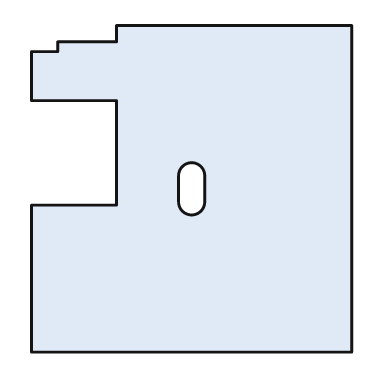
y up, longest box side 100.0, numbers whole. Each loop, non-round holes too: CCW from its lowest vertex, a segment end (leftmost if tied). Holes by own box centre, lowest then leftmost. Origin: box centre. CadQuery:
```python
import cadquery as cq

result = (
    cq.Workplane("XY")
    .moveTo(-49.0, -50.0)
    .lineTo(49.0, -50.0)
    .lineTo(49.0, 50.0)
    .lineTo(-23.0, 50.0)
    .lineTo(-23.0, 45.0)
    .lineTo(-41.0, 45.0)
    .lineTo(-41.0, 42.0)
    .lineTo(-49.0, 42.0)
    .lineTo(-49.0, 27.0)
    .lineTo(-23.0, 27.0)
    .lineTo(-23.0, -5.0)
    .lineTo(-49.0, -5.0)
    .close()
    .moveTo(-4.0, -4.0)
    .threePointArc((0.0, -8.0), (4.0, -4.0))
    .lineTo(4.0, 4.0)
    .threePointArc((0.0, 8.0), (-4.0, 4.0))
    .close()
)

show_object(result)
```